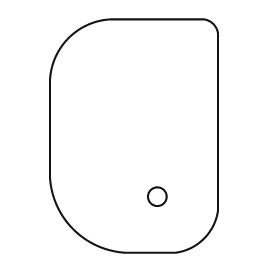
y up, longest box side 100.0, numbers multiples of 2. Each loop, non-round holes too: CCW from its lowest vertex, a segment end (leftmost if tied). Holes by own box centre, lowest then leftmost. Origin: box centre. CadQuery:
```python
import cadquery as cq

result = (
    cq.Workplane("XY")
    .moveTo(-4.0, -50.0)
    .lineTo(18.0, -50.0)
    .threePointArc((30.0, -44.0), (36.0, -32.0))
    .lineTo(36.0, 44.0)
    .threePointArc((34.0, 48.0), (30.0, 50.0))
    .lineTo(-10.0, 50.0)
    .threePointArc((-28.0, 42.0), (-36.0, 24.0))
    .lineTo(-36.0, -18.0)
    .threePointArc((-26.0, -40.0), (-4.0, -50.0))
    .close()
    .moveTo(10.0, -26.0)
    .circle(4.0)
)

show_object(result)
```